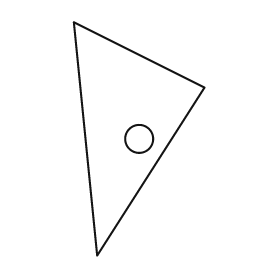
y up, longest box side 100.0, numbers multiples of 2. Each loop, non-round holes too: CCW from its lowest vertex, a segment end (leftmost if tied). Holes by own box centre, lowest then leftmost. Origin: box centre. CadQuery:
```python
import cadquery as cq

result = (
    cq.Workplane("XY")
    .moveTo(-18.0, -50.0)
    .lineTo(28.0, 22.0)
    .lineTo(-28.0, 50.0)
    .close()
    .moveTo(0.0, 0.0)
    .circle(6.0)
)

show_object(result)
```